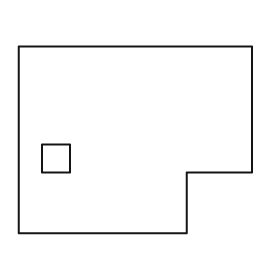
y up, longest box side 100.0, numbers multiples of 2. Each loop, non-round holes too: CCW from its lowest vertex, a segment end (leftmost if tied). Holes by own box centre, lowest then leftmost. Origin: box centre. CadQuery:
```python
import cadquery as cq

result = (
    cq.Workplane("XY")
    .moveTo(-50.0, -40.0)
    .lineTo(22.0, -40.0)
    .lineTo(22.0, -14.0)
    .lineTo(50.0, -14.0)
    .lineTo(50.0, 40.0)
    .lineTo(-50.0, 40.0)
    .close()
    .moveTo(-40.0, -14.0)
    .lineTo(-28.0, -14.0)
    .lineTo(-28.0, -2.0)
    .lineTo(-40.0, -2.0)
    .close()
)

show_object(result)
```